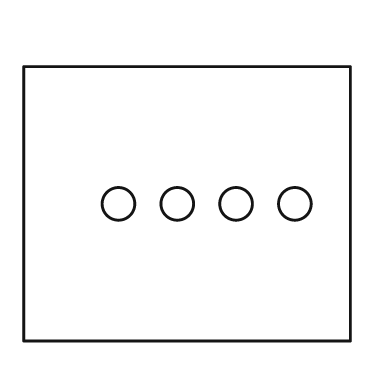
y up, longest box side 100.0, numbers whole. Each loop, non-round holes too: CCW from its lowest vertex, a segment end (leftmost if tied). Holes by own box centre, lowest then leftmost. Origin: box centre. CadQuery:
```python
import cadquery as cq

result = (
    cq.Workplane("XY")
    .moveTo(-50.0, -42.0)
    .lineTo(50.0, -42.0)
    .lineTo(50.0, 42.0)
    .lineTo(-50.0, 42.0)
    .close()
    .moveTo(-21.0, 0.0)
    .circle(5.0)
    .moveTo(-3.0, 0.0)
    .circle(5.0)
    .moveTo(15.0, 0.0)
    .circle(5.0)
    .moveTo(33.0, 0.0)
    .circle(5.0)
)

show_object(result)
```